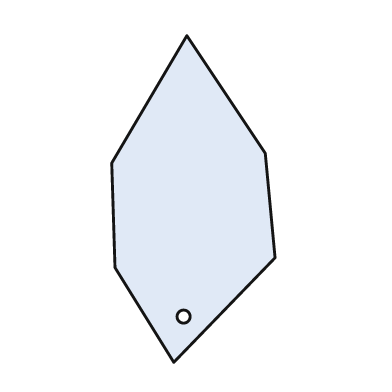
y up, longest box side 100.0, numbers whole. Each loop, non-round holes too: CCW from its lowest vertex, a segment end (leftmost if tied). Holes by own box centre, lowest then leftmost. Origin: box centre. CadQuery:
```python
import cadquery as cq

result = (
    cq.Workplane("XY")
    .moveTo(-6.0, -50.0)
    .lineTo(25.0, -18.0)
    .lineTo(22.0, 14.0)
    .lineTo(-2.0, 50.0)
    .lineTo(-25.0, 11.0)
    .lineTo(-24.0, -21.0)
    .close()
    .moveTo(-3.0, -36.0)
    .circle(2.0)
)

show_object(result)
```